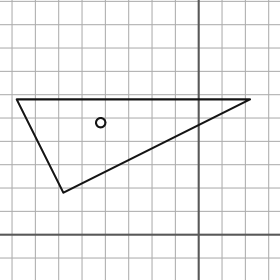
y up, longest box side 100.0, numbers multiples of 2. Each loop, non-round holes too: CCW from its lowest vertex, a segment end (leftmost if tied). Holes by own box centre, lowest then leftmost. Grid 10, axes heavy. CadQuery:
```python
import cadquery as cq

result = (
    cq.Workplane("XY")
    .moveTo(-58.0, 18.0)
    .lineTo(22.0, 58.0)
    .lineTo(-78.0, 58.0)
    .close()
    .moveTo(-42.0, 48.0)
    .circle(2.0)
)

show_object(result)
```